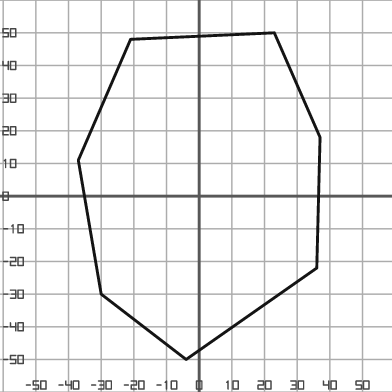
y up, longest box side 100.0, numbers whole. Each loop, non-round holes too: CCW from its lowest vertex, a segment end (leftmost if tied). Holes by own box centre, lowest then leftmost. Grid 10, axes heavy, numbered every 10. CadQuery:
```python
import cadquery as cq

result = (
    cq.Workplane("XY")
    .moveTo(-4.0, -50.0)
    .lineTo(36.0, -22.0)
    .lineTo(37.0, 18.0)
    .lineTo(23.0, 50.0)
    .lineTo(-21.0, 48.0)
    .lineTo(-37.0, 11.0)
    .lineTo(-30.0, -30.0)
    .close()
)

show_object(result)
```